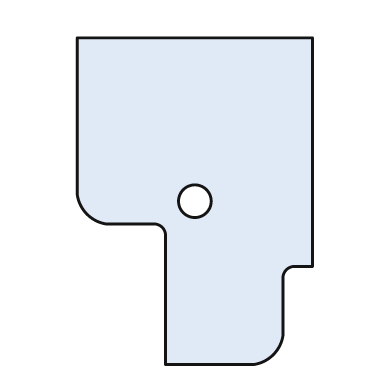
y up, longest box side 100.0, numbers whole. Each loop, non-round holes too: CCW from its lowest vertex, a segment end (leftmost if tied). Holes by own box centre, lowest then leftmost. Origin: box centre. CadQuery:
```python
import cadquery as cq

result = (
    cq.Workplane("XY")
    .moveTo(-9.0, -50.0)
    .lineTo(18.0, -50.0)
    .threePointArc((24.0, -47.0), (27.0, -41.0))
    .lineTo(27.0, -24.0)
    .threePointArc((28.0, -21.0), (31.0, -20.0))
    .lineTo(36.0, -20.0)
    .lineTo(36.0, 50.0)
    .lineTo(-36.0, 50.0)
    .lineTo(-36.0, 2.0)
    .threePointArc((-33.0, -4.0), (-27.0, -7.0))
    .lineTo(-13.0, -7.0)
    .threePointArc((-10.0, -8.0), (-9.0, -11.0))
    .close()
    .moveTo(0.0, 0.0)
    .circle(5.0)
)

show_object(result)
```